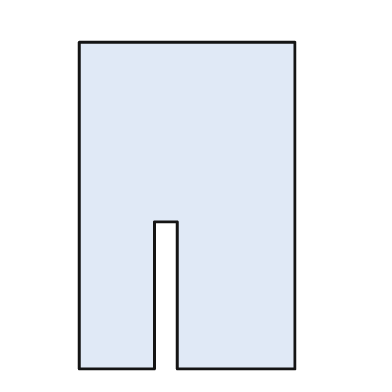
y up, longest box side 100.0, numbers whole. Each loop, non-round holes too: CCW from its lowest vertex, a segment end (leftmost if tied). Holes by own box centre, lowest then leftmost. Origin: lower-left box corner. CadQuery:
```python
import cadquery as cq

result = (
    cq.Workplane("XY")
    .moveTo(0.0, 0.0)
    .lineTo(23.0, 0.0)
    .lineTo(23.0, 45.0)
    .lineTo(30.0, 45.0)
    .lineTo(30.0, 0.0)
    .lineTo(66.0, 0.0)
    .lineTo(66.0, 100.0)
    .lineTo(0.0, 100.0)
    .close()
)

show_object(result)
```